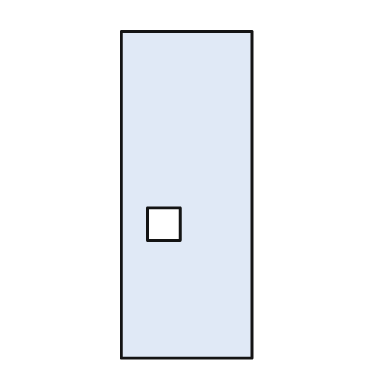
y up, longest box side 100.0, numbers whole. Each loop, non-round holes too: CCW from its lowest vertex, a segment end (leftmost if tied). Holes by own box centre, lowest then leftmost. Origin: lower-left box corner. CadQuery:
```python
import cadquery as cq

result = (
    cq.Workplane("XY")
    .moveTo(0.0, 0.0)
    .lineTo(40.0, 0.0)
    .lineTo(40.0, 100.0)
    .lineTo(0.0, 100.0)
    .close()
    .moveTo(8.0, 36.0)
    .lineTo(18.0, 36.0)
    .lineTo(18.0, 46.0)
    .lineTo(8.0, 46.0)
    .close()
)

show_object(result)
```